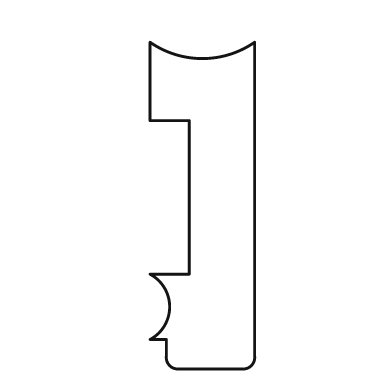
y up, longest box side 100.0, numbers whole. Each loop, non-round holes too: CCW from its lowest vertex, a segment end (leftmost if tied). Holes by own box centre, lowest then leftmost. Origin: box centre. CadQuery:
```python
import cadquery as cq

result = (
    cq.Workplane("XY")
    .moveTo(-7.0, -50.0)
    .lineTo(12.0, -50.0)
    .threePointArc((15.0, -49.0), (16.0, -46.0))
    .lineTo(16.0, 50.0)
    .threePointArc((0.0, 45.0), (-16.0, 50.0))
    .lineTo(-16.0, 26.0)
    .lineTo(-4.0, 26.0)
    .lineTo(-4.0, -21.0)
    .lineTo(-16.0, -21.0)
    .threePointArc((-10.0, -31.0), (-16.0, -41.0))
    .lineTo(-11.0, -41.0)
    .lineTo(-11.0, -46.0)
    .threePointArc((-10.0, -49.0), (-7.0, -50.0))
    .close()
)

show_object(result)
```